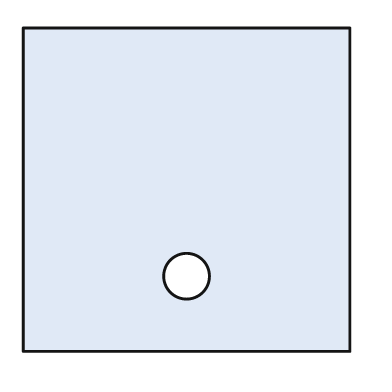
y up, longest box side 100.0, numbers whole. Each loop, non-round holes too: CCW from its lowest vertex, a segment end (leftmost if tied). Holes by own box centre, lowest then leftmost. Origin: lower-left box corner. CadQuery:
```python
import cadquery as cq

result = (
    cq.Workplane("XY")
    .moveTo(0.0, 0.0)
    .lineTo(100.0, 0.0)
    .lineTo(100.0, 99.0)
    .lineTo(0.0, 99.0)
    .close()
    .moveTo(50.0, 23.0)
    .circle(7.0)
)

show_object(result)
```